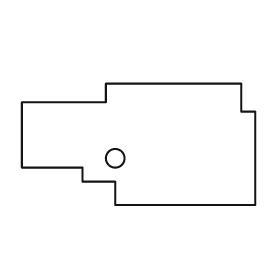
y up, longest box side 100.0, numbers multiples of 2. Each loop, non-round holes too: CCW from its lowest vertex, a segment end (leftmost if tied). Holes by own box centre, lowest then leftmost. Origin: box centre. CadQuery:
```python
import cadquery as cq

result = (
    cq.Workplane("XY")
    .moveTo(-10.0, -26.0)
    .lineTo(50.0, -26.0)
    .lineTo(50.0, 14.0)
    .lineTo(44.0, 14.0)
    .lineTo(44.0, 26.0)
    .lineTo(-14.0, 26.0)
    .lineTo(-14.0, 18.0)
    .lineTo(-50.0, 18.0)
    .lineTo(-50.0, -10.0)
    .lineTo(-24.0, -10.0)
    .lineTo(-24.0, -16.0)
    .lineTo(-10.0, -16.0)
    .close()
    .moveTo(-10.0, -6.0)
    .circle(4.0)
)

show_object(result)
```